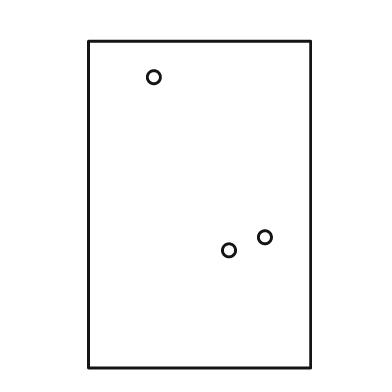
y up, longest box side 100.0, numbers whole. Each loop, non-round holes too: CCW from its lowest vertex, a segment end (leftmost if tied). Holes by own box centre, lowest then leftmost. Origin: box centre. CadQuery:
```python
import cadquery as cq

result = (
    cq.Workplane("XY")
    .moveTo(-34.0, -50.0)
    .lineTo(34.0, -50.0)
    .lineTo(34.0, 50.0)
    .lineTo(-34.0, 50.0)
    .close()
    .moveTo(9.0, -14.0)
    .circle(2.0)
    .moveTo(20.0, -10.0)
    .circle(2.0)
    .moveTo(-14.0, 39.0)
    .circle(2.0)
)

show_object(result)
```